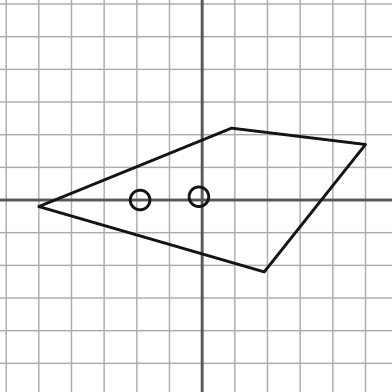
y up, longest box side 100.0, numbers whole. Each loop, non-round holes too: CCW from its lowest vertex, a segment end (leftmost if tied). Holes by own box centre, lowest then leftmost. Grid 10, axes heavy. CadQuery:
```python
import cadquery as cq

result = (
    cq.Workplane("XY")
    .moveTo(19.0, -22.0)
    .lineTo(50.0, 17.0)
    .lineTo(9.0, 22.0)
    .lineTo(-50.0, -2.0)
    .close()
    .moveTo(-19.0, 0.0)
    .circle(3.0)
    .moveTo(-1.0, 1.0)
    .circle(3.0)
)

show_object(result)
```